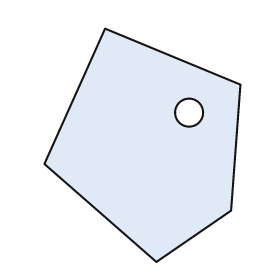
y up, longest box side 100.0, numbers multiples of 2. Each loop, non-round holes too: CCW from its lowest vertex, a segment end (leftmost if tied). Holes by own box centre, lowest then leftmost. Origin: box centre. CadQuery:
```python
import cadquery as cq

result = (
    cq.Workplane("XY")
    .moveTo(6.0, -50.0)
    .lineTo(38.0, -28.0)
    .lineTo(42.0, 26.0)
    .lineTo(-16.0, 50.0)
    .lineTo(-42.0, -8.0)
    .close()
    .moveTo(20.0, 14.0)
    .circle(6.0)
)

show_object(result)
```